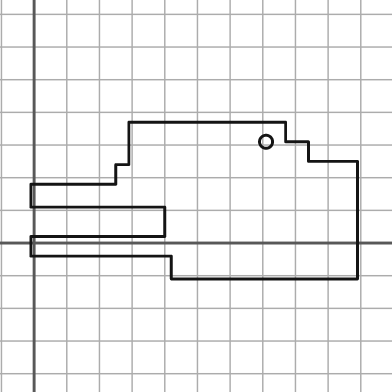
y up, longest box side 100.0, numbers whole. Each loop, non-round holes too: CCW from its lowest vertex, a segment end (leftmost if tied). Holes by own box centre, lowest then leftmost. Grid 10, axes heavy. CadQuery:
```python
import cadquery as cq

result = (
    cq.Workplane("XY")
    .moveTo(42.0, -11.0)
    .lineTo(99.0, -11.0)
    .lineTo(99.0, 25.0)
    .lineTo(84.0, 25.0)
    .lineTo(84.0, 31.0)
    .lineTo(77.0, 31.0)
    .lineTo(77.0, 37.0)
    .lineTo(29.0, 37.0)
    .lineTo(29.0, 24.0)
    .lineTo(25.0, 24.0)
    .lineTo(25.0, 18.0)
    .lineTo(-1.0, 18.0)
    .lineTo(-1.0, 11.0)
    .lineTo(40.0, 11.0)
    .lineTo(40.0, 2.0)
    .lineTo(-1.0, 2.0)
    .lineTo(-1.0, -4.0)
    .lineTo(42.0, -4.0)
    .close()
    .moveTo(71.0, 31.0)
    .circle(2.0)
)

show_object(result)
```